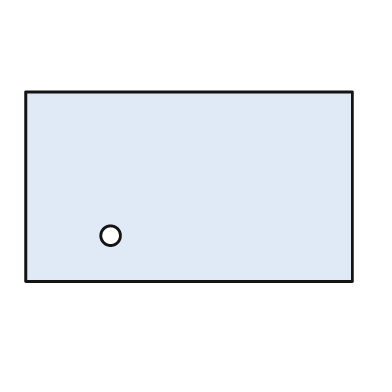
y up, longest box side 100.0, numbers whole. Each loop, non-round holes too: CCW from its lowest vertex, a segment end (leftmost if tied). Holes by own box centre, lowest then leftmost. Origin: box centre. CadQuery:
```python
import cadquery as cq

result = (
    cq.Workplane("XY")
    .moveTo(-50.0, -29.0)
    .lineTo(50.0, -29.0)
    .lineTo(50.0, 29.0)
    .lineTo(-50.0, 29.0)
    .close()
    .moveTo(-24.0, -15.0)
    .circle(3.0)
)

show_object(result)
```